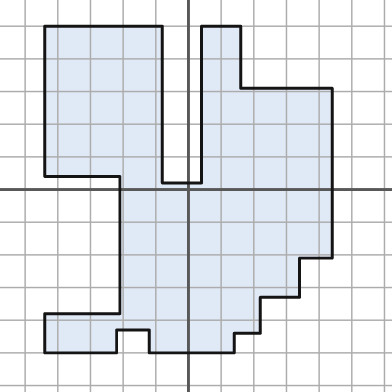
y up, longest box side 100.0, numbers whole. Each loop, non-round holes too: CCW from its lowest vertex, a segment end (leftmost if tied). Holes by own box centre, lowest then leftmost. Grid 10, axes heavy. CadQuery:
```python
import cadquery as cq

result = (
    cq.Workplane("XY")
    .moveTo(-44.0, -50.0)
    .lineTo(-22.0, -50.0)
    .lineTo(-22.0, -43.0)
    .lineTo(-12.0, -43.0)
    .lineTo(-12.0, -50.0)
    .lineTo(14.0, -50.0)
    .lineTo(14.0, -44.0)
    .lineTo(22.0, -44.0)
    .lineTo(22.0, -33.0)
    .lineTo(34.0, -33.0)
    .lineTo(34.0, -21.0)
    .lineTo(44.0, -21.0)
    .lineTo(44.0, 31.0)
    .lineTo(16.0, 31.0)
    .lineTo(16.0, 50.0)
    .lineTo(4.0, 50.0)
    .lineTo(4.0, 2.0)
    .lineTo(-8.0, 2.0)
    .lineTo(-8.0, 50.0)
    .lineTo(-44.0, 50.0)
    .lineTo(-44.0, 4.0)
    .lineTo(-21.0, 4.0)
    .lineTo(-21.0, -38.0)
    .lineTo(-44.0, -38.0)
    .close()
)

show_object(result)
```